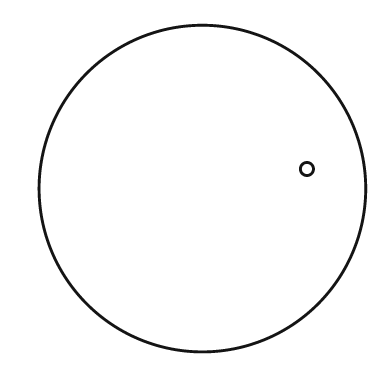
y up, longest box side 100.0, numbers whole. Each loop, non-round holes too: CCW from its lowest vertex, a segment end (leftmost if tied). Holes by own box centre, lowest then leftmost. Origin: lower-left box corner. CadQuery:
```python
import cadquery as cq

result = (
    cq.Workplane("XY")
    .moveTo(50.0, 50.0)
    .circle(50.0)
    .moveTo(82.0, 56.0)
    .circle(2.0)
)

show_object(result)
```